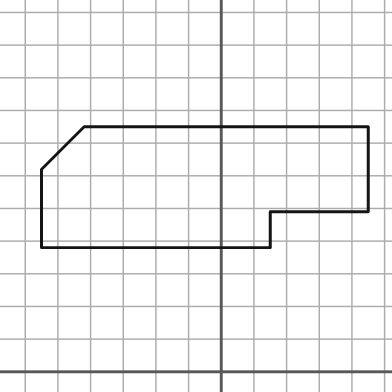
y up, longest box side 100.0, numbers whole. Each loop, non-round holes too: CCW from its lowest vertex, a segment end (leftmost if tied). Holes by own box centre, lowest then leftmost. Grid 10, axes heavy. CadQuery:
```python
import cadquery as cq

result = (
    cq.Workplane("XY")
    .moveTo(-55.0, 38.0)
    .lineTo(15.0, 38.0)
    .lineTo(15.0, 49.0)
    .lineTo(45.0, 49.0)
    .lineTo(45.0, 75.0)
    .lineTo(-42.0, 75.0)
    .lineTo(-55.0, 62.0)
    .close()
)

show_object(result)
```